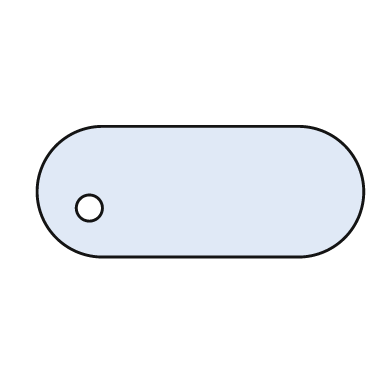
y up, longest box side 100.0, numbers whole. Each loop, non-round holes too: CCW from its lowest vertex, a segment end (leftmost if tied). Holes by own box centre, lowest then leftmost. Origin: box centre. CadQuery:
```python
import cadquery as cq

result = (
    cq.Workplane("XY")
    .moveTo(-30.0, -20.0)
    .lineTo(30.0, -20.0)
    .threePointArc((50.0, 0.0), (30.0, 20.0))
    .lineTo(-30.0, 20.0)
    .threePointArc((-50.0, 0.0), (-30.0, -20.0))
    .close()
    .moveTo(-34.0, -5.0)
    .circle(4.0)
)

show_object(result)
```